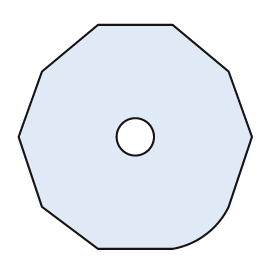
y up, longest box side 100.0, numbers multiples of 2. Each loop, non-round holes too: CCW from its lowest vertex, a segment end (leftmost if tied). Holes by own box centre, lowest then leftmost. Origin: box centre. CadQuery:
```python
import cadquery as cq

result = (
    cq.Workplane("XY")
    .moveTo(-16.0, -48.0)
    .lineTo(16.0, -48.0)
    .threePointArc((30.0, -42.0), (40.0, -30.0))
    .lineTo(50.0, 0.0)
    .lineTo(40.0, 28.0)
    .lineTo(16.0, 48.0)
    .lineTo(-16.0, 48.0)
    .lineTo(-40.0, 28.0)
    .lineTo(-50.0, 0.0)
    .lineTo(-40.0, -30.0)
    .close()
    .moveTo(0.0, 0.0)
    .circle(8.0)
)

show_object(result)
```